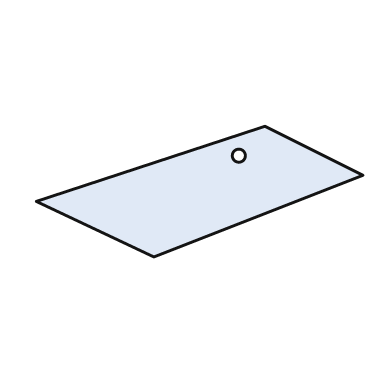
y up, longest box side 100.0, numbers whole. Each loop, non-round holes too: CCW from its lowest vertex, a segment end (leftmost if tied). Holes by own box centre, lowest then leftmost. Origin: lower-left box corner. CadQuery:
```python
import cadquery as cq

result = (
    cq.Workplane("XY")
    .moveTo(36.0, 0.0)
    .lineTo(100.0, 25.0)
    .lineTo(70.0, 40.0)
    .lineTo(0.0, 17.0)
    .close()
    .moveTo(62.0, 31.0)
    .circle(2.0)
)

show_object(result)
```